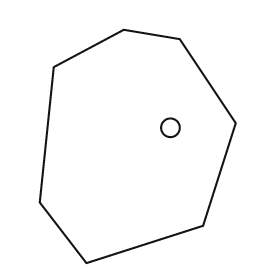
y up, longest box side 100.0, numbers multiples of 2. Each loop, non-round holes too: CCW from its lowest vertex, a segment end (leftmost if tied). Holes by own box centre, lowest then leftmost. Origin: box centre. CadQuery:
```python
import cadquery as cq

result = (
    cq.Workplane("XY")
    .moveTo(-22.0, -50.0)
    .lineTo(28.0, -34.0)
    .lineTo(42.0, 10.0)
    .lineTo(18.0, 46.0)
    .lineTo(-6.0, 50.0)
    .lineTo(-36.0, 34.0)
    .lineTo(-42.0, -24.0)
    .close()
    .moveTo(14.0, 8.0)
    .circle(4.0)
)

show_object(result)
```